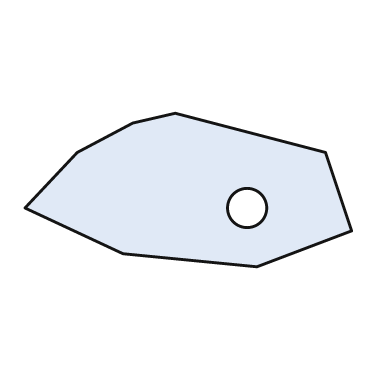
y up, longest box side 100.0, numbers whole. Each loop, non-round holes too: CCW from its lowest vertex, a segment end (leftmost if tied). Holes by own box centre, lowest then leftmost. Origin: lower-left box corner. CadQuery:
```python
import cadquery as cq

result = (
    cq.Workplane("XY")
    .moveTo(71.0, 0.0)
    .lineTo(100.0, 11.0)
    .lineTo(92.0, 35.0)
    .lineTo(46.0, 47.0)
    .lineTo(33.0, 44.0)
    .lineTo(16.0, 35.0)
    .lineTo(0.0, 18.0)
    .lineTo(30.0, 4.0)
    .close()
    .moveTo(68.0, 18.0)
    .circle(6.0)
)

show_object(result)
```